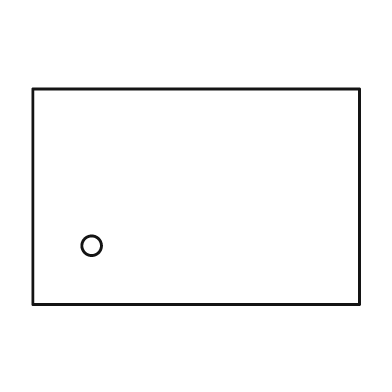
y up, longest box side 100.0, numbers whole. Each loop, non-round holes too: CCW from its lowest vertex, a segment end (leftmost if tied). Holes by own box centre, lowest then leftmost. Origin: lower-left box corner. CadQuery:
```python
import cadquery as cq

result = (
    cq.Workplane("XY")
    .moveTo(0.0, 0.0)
    .lineTo(100.0, 0.0)
    .lineTo(100.0, 66.0)
    .lineTo(0.0, 66.0)
    .close()
    .moveTo(18.0, 18.0)
    .circle(3.0)
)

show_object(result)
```